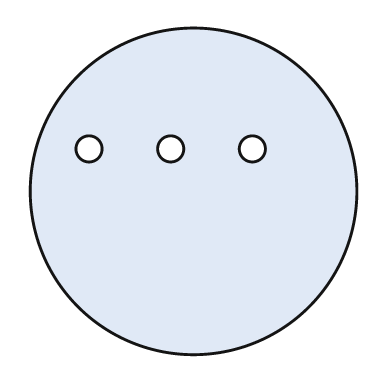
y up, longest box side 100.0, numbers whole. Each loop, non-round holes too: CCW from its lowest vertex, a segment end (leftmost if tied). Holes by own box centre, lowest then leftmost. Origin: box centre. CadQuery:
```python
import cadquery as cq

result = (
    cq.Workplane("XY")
    .moveTo(0.0, 0.0)
    .circle(50.0)
    .moveTo(-32.0, 13.0)
    .circle(4.0)
    .moveTo(-7.0, 13.0)
    .circle(4.0)
    .moveTo(18.0, 13.0)
    .circle(4.0)
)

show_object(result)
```